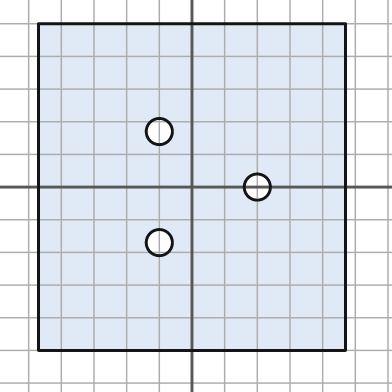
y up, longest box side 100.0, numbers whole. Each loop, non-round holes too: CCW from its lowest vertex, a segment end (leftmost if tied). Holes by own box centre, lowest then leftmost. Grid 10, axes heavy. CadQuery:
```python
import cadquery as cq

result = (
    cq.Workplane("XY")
    .moveTo(-47.0, -50.0)
    .lineTo(47.0, -50.0)
    .lineTo(47.0, 50.0)
    .lineTo(-47.0, 50.0)
    .close()
    .moveTo(-10.0, -17.0)
    .circle(4.0)
    .moveTo(20.0, 0.0)
    .circle(4.0)
    .moveTo(-10.0, 17.0)
    .circle(4.0)
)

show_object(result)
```